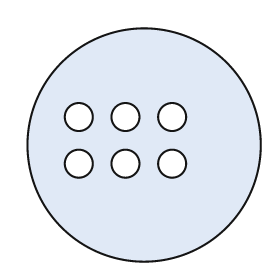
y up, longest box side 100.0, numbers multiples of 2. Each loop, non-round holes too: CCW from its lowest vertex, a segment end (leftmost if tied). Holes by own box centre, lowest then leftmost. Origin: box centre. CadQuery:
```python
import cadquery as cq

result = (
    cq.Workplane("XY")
    .moveTo(0.0, 0.0)
    .circle(50.0)
    .moveTo(-28.0, -8.0)
    .circle(6.0)
    .moveTo(-8.0, -8.0)
    .circle(6.0)
    .moveTo(12.0, -8.0)
    .circle(6.0)
    .moveTo(-28.0, 12.0)
    .circle(6.0)
    .moveTo(-8.0, 12.0)
    .circle(6.0)
    .moveTo(12.0, 12.0)
    .circle(6.0)
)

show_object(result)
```